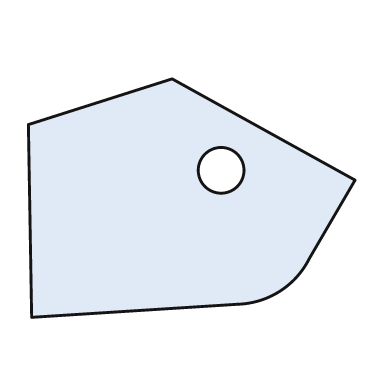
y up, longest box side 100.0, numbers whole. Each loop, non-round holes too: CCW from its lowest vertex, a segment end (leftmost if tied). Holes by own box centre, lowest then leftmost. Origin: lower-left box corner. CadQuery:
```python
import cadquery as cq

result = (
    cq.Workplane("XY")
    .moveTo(1.0, 0.0)
    .lineTo(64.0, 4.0)
    .threePointArc((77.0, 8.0), (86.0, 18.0))
    .lineTo(100.0, 42.0)
    .lineTo(44.0, 73.0)
    .lineTo(0.0, 59.0)
    .close()
    .moveTo(59.0, 45.0)
    .circle(7.0)
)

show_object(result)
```